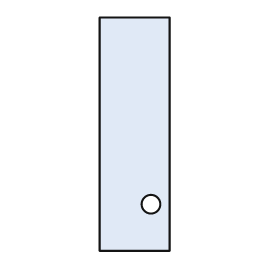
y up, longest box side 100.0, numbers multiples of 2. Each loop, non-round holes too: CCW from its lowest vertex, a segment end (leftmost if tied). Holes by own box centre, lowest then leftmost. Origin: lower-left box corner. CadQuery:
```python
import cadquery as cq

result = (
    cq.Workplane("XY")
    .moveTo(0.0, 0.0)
    .lineTo(30.0, 0.0)
    .lineTo(30.0, 100.0)
    .lineTo(0.0, 100.0)
    .close()
    .moveTo(22.0, 20.0)
    .circle(4.0)
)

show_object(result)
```